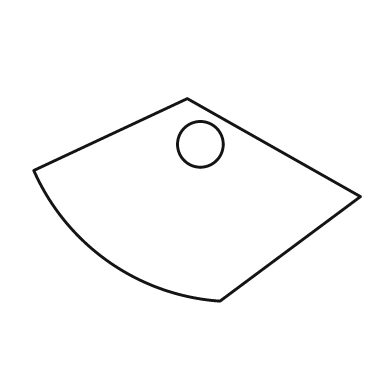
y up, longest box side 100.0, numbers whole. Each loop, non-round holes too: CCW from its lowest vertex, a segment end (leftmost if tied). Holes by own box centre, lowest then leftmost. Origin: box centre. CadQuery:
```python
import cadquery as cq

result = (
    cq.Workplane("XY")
    .moveTo(7.0, -31.0)
    .lineTo(50.0, 1.0)
    .lineTo(-3.0, 31.0)
    .lineTo(-50.0, 9.0)
    .threePointArc((-27.0, -19.0), (7.0, -31.0))
    .close()
    .moveTo(1.0, 17.0)
    .circle(7.0)
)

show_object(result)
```